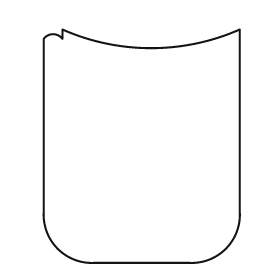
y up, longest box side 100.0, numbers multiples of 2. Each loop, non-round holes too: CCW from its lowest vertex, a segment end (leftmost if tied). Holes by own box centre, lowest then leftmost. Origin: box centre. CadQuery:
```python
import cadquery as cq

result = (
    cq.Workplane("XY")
    .moveTo(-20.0, -50.0)
    .lineTo(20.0, -50.0)
    .threePointArc((36.0, -44.0), (42.0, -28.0))
    .lineTo(42.0, 50.0)
    .threePointArc((4.0, 42.0), (-34.0, 50.0))
    .lineTo(-34.0, 46.0)
    .threePointArc((-38.0, 48.0), (-42.0, 46.0))
    .lineTo(-42.0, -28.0)
    .threePointArc((-36.0, -44.0), (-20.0, -50.0))
    .close()
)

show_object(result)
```